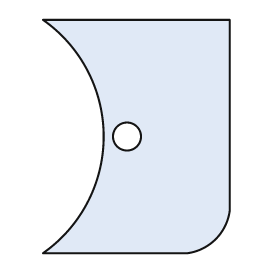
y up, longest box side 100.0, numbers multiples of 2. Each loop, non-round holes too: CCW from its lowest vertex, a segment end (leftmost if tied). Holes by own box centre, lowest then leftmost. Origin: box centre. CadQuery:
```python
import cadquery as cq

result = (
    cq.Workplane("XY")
    .moveTo(-40.0, -50.0)
    .lineTo(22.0, -50.0)
    .threePointArc((34.0, -44.0), (40.0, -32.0))
    .lineTo(40.0, 50.0)
    .lineTo(-40.0, 50.0)
    .threePointArc((-14.0, 0.0), (-40.0, -50.0))
    .close()
    .moveTo(-4.0, 0.0)
    .circle(6.0)
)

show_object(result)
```